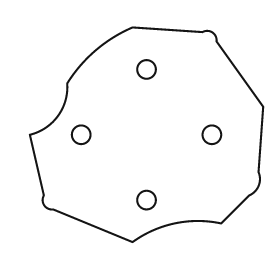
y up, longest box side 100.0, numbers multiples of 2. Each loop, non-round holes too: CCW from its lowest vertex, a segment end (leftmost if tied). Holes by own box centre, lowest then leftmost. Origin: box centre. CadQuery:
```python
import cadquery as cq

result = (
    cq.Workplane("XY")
    .moveTo(-6.0, -46.0)
    .threePointArc((12.0, -38.0), (32.0, -38.0))
    .lineTo(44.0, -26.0)
    .threePointArc((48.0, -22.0), (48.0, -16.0))
    .lineTo(50.0, 12.0)
    .lineTo(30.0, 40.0)
    .threePointArc((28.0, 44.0), (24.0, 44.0))
    .lineTo(-6.0, 46.0)
    .threePointArc((-22.0, 36.0), (-34.0, 22.0))
    .threePointArc((-38.0, 8.0), (-50.0, 0.0))
    .lineTo(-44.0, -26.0)
    .threePointArc((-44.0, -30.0), (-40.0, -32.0))
    .close()
    .moveTo(0.0, -28.0)
    .circle(4.0)
    .moveTo(-28.0, 0.0)
    .circle(4.0)
    .moveTo(28.0, 0.0)
    .circle(4.0)
    .moveTo(0.0, 28.0)
    .circle(4.0)
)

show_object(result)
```